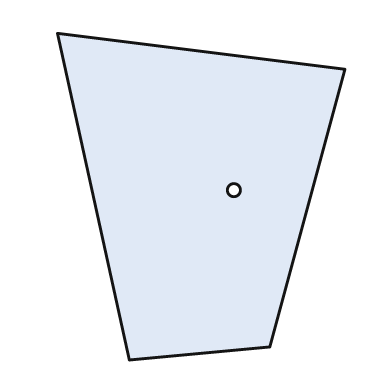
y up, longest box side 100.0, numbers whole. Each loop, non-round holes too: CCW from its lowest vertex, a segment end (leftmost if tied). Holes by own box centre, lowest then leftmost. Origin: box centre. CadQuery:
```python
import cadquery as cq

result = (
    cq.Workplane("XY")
    .moveTo(-22.0, -50.0)
    .lineTo(21.0, -46.0)
    .lineTo(44.0, 39.0)
    .lineTo(-44.0, 50.0)
    .close()
    .moveTo(10.0, 2.0)
    .circle(2.0)
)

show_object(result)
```